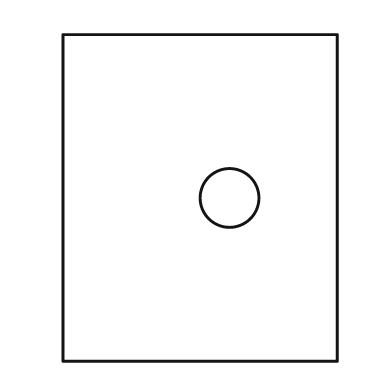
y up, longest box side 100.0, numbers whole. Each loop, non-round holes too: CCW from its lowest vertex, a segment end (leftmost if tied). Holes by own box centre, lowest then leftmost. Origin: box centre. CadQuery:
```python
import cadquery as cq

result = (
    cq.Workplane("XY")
    .moveTo(-42.0, -50.0)
    .lineTo(42.0, -50.0)
    .lineTo(42.0, 50.0)
    .lineTo(-42.0, 50.0)
    .close()
    .moveTo(9.0, 0.0)
    .circle(9.0)
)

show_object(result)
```